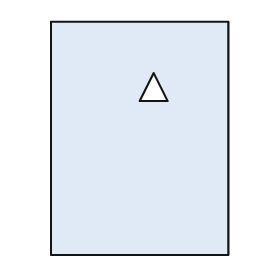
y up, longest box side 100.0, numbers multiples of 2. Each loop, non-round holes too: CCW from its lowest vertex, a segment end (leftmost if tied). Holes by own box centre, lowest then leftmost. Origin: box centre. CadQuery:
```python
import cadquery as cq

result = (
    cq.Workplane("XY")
    .moveTo(-38.0, -50.0)
    .lineTo(38.0, -50.0)
    .lineTo(38.0, 50.0)
    .lineTo(-38.0, 50.0)
    .close()
    .moveTo(0.0, 16.0)
    .lineTo(12.0, 16.0)
    .lineTo(6.0, 28.0)
    .close()
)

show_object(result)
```